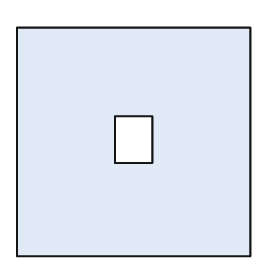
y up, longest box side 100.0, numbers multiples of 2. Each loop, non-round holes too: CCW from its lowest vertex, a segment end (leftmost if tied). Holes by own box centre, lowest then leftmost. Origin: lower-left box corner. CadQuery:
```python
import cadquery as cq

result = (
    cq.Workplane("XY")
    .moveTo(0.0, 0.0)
    .lineTo(100.0, 0.0)
    .lineTo(100.0, 98.0)
    .lineTo(0.0, 98.0)
    .close()
    .moveTo(42.0, 40.0)
    .lineTo(58.0, 40.0)
    .lineTo(58.0, 60.0)
    .lineTo(42.0, 60.0)
    .close()
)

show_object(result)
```